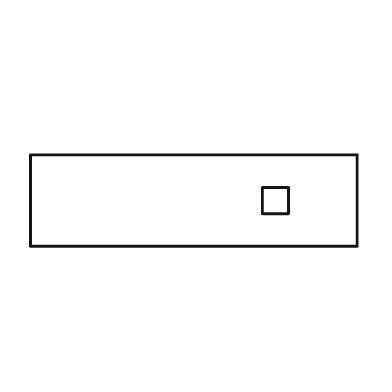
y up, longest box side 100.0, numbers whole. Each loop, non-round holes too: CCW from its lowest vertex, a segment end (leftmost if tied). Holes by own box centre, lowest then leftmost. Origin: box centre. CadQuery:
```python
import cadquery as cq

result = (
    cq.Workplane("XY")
    .moveTo(-50.0, -14.0)
    .lineTo(50.0, -14.0)
    .lineTo(50.0, 14.0)
    .lineTo(-50.0, 14.0)
    .close()
    .moveTo(21.0, -4.0)
    .lineTo(29.0, -4.0)
    .lineTo(29.0, 4.0)
    .lineTo(21.0, 4.0)
    .close()
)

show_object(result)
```